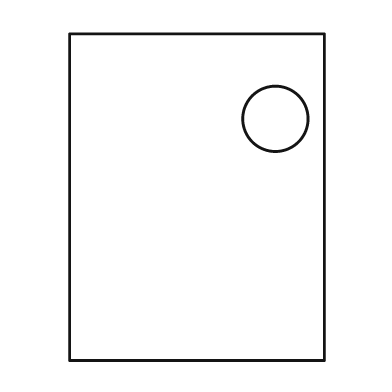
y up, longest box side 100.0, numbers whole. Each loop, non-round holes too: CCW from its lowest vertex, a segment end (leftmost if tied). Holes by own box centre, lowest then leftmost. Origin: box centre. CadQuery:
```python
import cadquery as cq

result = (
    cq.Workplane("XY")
    .moveTo(-39.0, -50.0)
    .lineTo(39.0, -50.0)
    .lineTo(39.0, 50.0)
    .lineTo(-39.0, 50.0)
    .close()
    .moveTo(24.0, 24.0)
    .circle(10.0)
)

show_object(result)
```